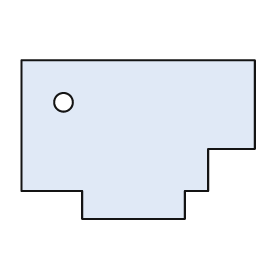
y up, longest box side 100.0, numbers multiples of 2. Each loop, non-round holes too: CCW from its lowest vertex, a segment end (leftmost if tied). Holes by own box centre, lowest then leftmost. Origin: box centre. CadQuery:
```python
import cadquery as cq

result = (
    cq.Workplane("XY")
    .moveTo(-24.0, -34.0)
    .lineTo(20.0, -34.0)
    .lineTo(20.0, -22.0)
    .lineTo(30.0, -22.0)
    .lineTo(30.0, -4.0)
    .lineTo(50.0, -4.0)
    .lineTo(50.0, 34.0)
    .lineTo(-50.0, 34.0)
    .lineTo(-50.0, -22.0)
    .lineTo(-24.0, -22.0)
    .close()
    .moveTo(-32.0, 16.0)
    .circle(4.0)
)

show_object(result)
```